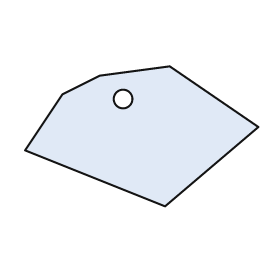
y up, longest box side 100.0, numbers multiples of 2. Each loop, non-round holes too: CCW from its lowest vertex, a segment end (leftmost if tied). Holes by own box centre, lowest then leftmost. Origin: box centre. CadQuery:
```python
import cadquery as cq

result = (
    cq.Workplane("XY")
    .moveTo(10.0, -30.0)
    .lineTo(50.0, 4.0)
    .lineTo(12.0, 30.0)
    .lineTo(-18.0, 26.0)
    .lineTo(-34.0, 18.0)
    .lineTo(-50.0, -6.0)
    .close()
    .moveTo(-8.0, 16.0)
    .circle(4.0)
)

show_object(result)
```